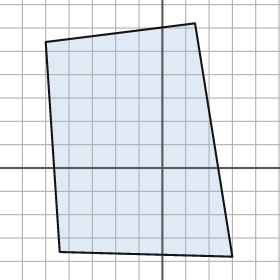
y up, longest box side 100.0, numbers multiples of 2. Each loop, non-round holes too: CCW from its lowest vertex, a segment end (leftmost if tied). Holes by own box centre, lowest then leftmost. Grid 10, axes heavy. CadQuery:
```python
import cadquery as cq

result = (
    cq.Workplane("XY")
    .moveTo(30.0, -38.0)
    .lineTo(14.0, 62.0)
    .lineTo(-50.0, 54.0)
    .lineTo(-44.0, -36.0)
    .close()
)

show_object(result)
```